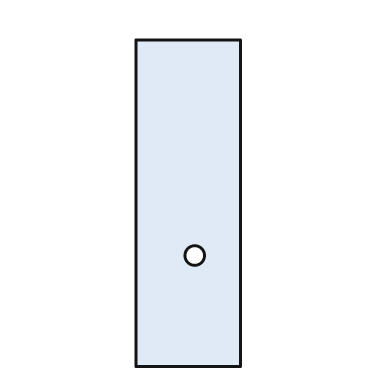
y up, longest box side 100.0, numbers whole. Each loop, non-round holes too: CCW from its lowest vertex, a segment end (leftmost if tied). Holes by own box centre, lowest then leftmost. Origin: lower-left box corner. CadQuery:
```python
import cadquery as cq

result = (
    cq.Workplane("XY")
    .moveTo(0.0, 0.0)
    .lineTo(32.0, 0.0)
    .lineTo(32.0, 100.0)
    .lineTo(0.0, 100.0)
    .close()
    .moveTo(18.0, 34.0)
    .circle(3.0)
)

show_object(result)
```